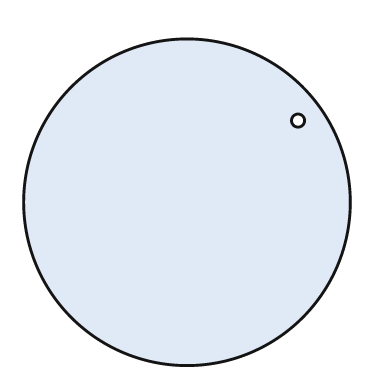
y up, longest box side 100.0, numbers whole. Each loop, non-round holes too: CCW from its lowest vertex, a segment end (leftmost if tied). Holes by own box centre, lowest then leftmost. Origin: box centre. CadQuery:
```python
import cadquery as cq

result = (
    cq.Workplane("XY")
    .moveTo(0.0, 0.0)
    .circle(50.0)
    .moveTo(34.0, 25.0)
    .circle(2.0)
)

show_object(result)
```